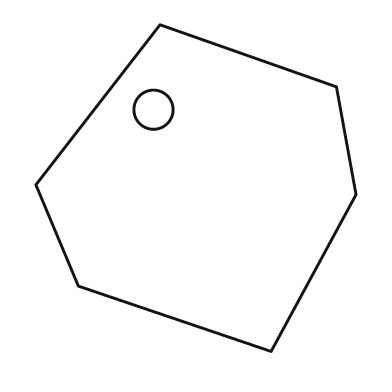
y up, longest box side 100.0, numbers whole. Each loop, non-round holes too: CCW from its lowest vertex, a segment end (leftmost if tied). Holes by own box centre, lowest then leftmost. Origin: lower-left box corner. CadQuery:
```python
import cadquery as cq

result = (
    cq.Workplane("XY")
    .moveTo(72.0, 0.0)
    .lineTo(98.0, 48.0)
    .lineTo(92.0, 81.0)
    .lineTo(38.0, 100.0)
    .lineTo(0.0, 51.0)
    .lineTo(13.0, 20.0)
    .close()
    .moveTo(36.0, 74.0)
    .circle(6.0)
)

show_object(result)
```